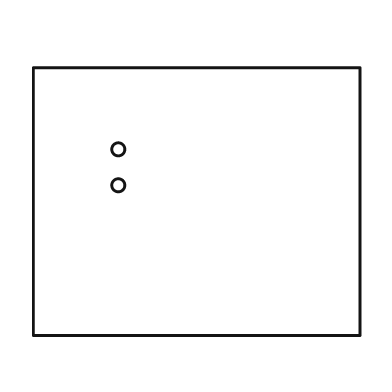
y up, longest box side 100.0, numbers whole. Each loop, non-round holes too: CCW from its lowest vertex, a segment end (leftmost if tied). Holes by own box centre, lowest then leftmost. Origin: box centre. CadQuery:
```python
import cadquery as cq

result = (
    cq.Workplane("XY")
    .moveTo(-50.0, -41.0)
    .lineTo(50.0, -41.0)
    .lineTo(50.0, 41.0)
    .lineTo(-50.0, 41.0)
    .close()
    .moveTo(-24.0, 5.0)
    .circle(2.0)
    .moveTo(-24.0, 16.0)
    .circle(2.0)
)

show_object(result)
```